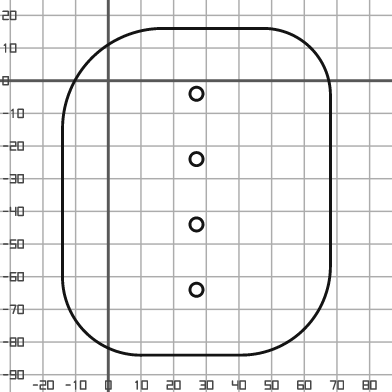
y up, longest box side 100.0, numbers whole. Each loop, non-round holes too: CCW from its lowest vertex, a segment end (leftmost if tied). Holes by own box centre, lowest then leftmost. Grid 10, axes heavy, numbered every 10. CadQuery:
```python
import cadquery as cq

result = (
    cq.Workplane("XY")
    .moveTo(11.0, -84.0)
    .lineTo(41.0, -84.0)
    .threePointArc((60.0, -76.0), (68.0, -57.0))
    .lineTo(68.0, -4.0)
    .threePointArc((62.0, 10.0), (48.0, 16.0))
    .lineTo(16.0, 16.0)
    .threePointArc((-5.0, 7.0), (-14.0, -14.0))
    .lineTo(-14.0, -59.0)
    .threePointArc((-7.0, -77.0), (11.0, -84.0))
    .close()
    .moveTo(27.0, -64.0)
    .circle(2.0)
    .moveTo(27.0, -44.0)
    .circle(2.0)
    .moveTo(27.0, -24.0)
    .circle(2.0)
    .moveTo(27.0, -4.0)
    .circle(2.0)
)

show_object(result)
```